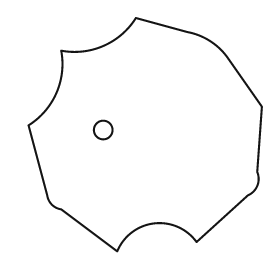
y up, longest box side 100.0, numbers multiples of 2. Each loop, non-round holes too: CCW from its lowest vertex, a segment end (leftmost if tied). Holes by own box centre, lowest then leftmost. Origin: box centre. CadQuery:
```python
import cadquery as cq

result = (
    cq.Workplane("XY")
    .moveTo(-12.0, -50.0)
    .threePointArc((4.0, -38.0), (22.0, -46.0))
    .lineTo(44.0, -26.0)
    .threePointArc((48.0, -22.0), (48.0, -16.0))
    .lineTo(50.0, 12.0)
    .lineTo(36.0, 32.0)
    .threePointArc((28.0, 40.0), (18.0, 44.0))
    .lineTo(-4.0, 50.0)
    .threePointArc((-18.0, 38.0), (-36.0, 36.0))
    .threePointArc((-38.0, 18.0), (-50.0, 4.0))
    .lineTo(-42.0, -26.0)
    .threePointArc((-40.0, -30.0), (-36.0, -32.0))
    .close()
    .moveTo(-18.0, 2.0)
    .circle(4.0)
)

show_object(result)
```